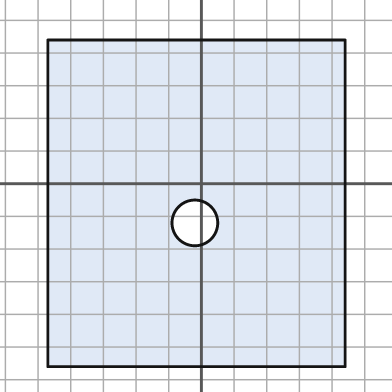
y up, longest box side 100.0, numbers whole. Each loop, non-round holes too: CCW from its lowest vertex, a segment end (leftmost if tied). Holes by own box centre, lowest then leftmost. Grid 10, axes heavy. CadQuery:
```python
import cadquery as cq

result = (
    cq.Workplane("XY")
    .moveTo(-47.0, -56.0)
    .lineTo(44.0, -56.0)
    .lineTo(44.0, 44.0)
    .lineTo(-47.0, 44.0)
    .close()
    .moveTo(-2.0, -12.0)
    .circle(7.0)
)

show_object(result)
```